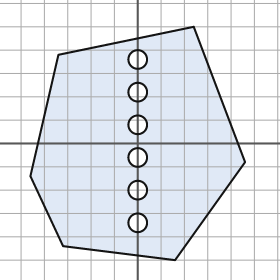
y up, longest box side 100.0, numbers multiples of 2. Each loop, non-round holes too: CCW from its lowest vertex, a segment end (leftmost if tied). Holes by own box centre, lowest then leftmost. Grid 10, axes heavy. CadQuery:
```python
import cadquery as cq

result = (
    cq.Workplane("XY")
    .moveTo(16.0, -50.0)
    .lineTo(46.0, -8.0)
    .lineTo(24.0, 50.0)
    .lineTo(-34.0, 38.0)
    .lineTo(-46.0, -14.0)
    .lineTo(-32.0, -44.0)
    .close()
    .moveTo(0.0, -34.0)
    .circle(4.0)
    .moveTo(0.0, -20.0)
    .circle(4.0)
    .moveTo(0.0, -6.0)
    .circle(4.0)
    .moveTo(0.0, 8.0)
    .circle(4.0)
    .moveTo(0.0, 22.0)
    .circle(4.0)
    .moveTo(0.0, 36.0)
    .circle(4.0)
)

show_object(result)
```